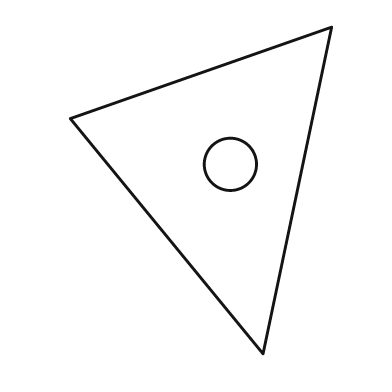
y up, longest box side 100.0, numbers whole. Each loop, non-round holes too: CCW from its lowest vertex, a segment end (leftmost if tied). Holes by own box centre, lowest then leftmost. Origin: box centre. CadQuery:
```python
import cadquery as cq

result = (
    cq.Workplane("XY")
    .moveTo(19.0, -50.0)
    .lineTo(40.0, 50.0)
    .lineTo(-40.0, 22.0)
    .close()
    .moveTo(9.0, 8.0)
    .circle(8.0)
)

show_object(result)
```